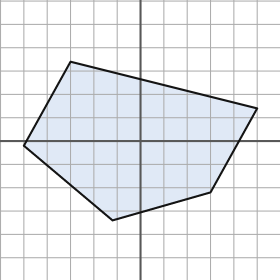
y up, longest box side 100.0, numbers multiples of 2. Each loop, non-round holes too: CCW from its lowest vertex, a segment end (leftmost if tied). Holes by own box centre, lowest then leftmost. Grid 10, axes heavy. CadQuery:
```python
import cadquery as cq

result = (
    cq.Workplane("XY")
    .moveTo(-12.0, -34.0)
    .lineTo(30.0, -22.0)
    .lineTo(50.0, 14.0)
    .lineTo(-30.0, 34.0)
    .lineTo(-50.0, -2.0)
    .close()
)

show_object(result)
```